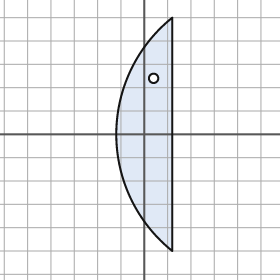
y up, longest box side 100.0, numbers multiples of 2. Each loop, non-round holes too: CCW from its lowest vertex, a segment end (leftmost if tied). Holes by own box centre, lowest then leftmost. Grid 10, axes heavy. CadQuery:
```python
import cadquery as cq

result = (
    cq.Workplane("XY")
    .moveTo(12.0, -50.0)
    .lineTo(12.0, 50.0)
    .threePointArc((-12.0, 0.0), (12.0, -50.0))
    .close()
    .moveTo(4.0, 24.0)
    .circle(2.0)
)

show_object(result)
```